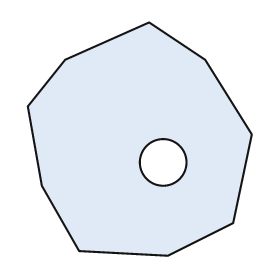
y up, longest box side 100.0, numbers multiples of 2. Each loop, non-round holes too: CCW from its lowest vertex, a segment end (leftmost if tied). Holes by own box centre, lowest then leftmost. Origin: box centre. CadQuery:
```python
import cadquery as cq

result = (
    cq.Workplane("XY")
    .moveTo(12.0, -50.0)
    .lineTo(40.0, -36.0)
    .lineTo(48.0, 2.0)
    .lineTo(28.0, 34.0)
    .lineTo(4.0, 50.0)
    .lineTo(-32.0, 34.0)
    .lineTo(-48.0, 14.0)
    .lineTo(-42.0, -20.0)
    .lineTo(-26.0, -48.0)
    .close()
    .moveTo(10.0, -10.0)
    .circle(10.0)
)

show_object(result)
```